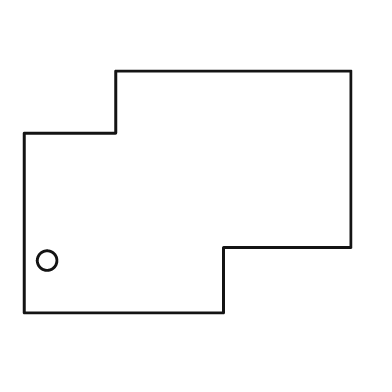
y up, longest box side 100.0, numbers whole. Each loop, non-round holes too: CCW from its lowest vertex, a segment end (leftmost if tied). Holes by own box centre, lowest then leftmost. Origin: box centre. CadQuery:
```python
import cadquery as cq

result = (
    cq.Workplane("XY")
    .moveTo(-50.0, -37.0)
    .lineTo(11.0, -37.0)
    .lineTo(11.0, -17.0)
    .lineTo(50.0, -17.0)
    .lineTo(50.0, 37.0)
    .lineTo(-22.0, 37.0)
    .lineTo(-22.0, 18.0)
    .lineTo(-50.0, 18.0)
    .close()
    .moveTo(-43.0, -21.0)
    .circle(3.0)
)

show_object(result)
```